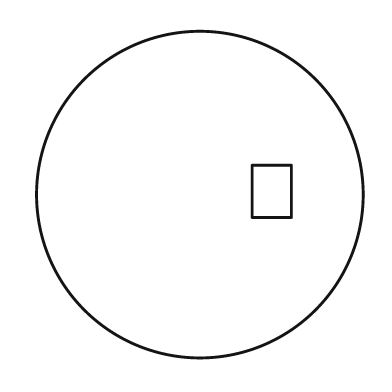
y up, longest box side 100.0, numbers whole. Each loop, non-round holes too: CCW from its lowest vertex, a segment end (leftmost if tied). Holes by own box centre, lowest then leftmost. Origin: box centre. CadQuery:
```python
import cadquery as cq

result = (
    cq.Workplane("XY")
    .moveTo(0.0, 0.0)
    .circle(50.0)
    .moveTo(16.0, -7.0)
    .lineTo(28.0, -7.0)
    .lineTo(28.0, 9.0)
    .lineTo(16.0, 9.0)
    .close()
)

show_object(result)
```